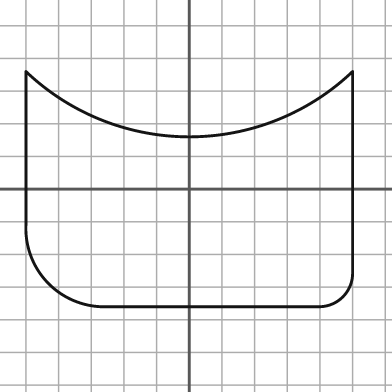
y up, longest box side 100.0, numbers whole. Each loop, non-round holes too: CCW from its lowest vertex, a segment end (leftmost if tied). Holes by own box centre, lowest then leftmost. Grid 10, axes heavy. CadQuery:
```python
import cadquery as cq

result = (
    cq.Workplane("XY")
    .moveTo(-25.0, -36.0)
    .lineTo(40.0, -36.0)
    .threePointArc((47.0, -33.0), (50.0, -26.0))
    .lineTo(50.0, 36.0)
    .threePointArc((0.0, 16.0), (-50.0, 36.0))
    .lineTo(-50.0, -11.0)
    .threePointArc((-43.0, -29.0), (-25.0, -36.0))
    .close()
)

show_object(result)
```